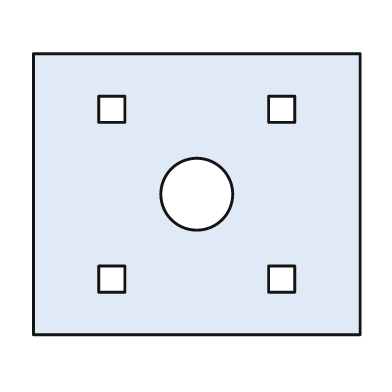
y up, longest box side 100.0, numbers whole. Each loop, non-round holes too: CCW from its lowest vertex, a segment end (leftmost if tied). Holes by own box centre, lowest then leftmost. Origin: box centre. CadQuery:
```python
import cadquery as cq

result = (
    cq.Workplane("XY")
    .moveTo(-50.0, -43.0)
    .lineTo(50.0, -43.0)
    .lineTo(50.0, 43.0)
    .lineTo(-50.0, 43.0)
    .close()
    .moveTo(-30.0, -30.0)
    .lineTo(-22.0, -30.0)
    .lineTo(-22.0, -22.0)
    .lineTo(-30.0, -22.0)
    .close()
    .moveTo(22.0, -30.0)
    .lineTo(30.0, -30.0)
    .lineTo(30.0, -22.0)
    .lineTo(22.0, -22.0)
    .close()
    .moveTo(0.0, 0.0)
    .circle(11.0)
    .moveTo(-30.0, 22.0)
    .lineTo(-22.0, 22.0)
    .lineTo(-22.0, 30.0)
    .lineTo(-30.0, 30.0)
    .close()
    .moveTo(22.0, 22.0)
    .lineTo(30.0, 22.0)
    .lineTo(30.0, 30.0)
    .lineTo(22.0, 30.0)
    .close()
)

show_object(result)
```